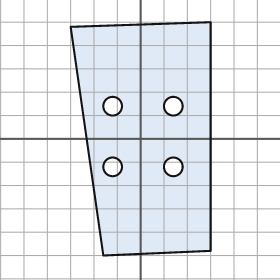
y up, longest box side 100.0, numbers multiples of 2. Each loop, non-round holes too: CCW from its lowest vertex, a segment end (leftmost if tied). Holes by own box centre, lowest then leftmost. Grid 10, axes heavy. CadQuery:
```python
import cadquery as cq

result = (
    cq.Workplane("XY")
    .moveTo(-16.0, -50.0)
    .lineTo(30.0, -48.0)
    .lineTo(30.0, 50.0)
    .lineTo(-30.0, 48.0)
    .close()
    .moveTo(-12.0, -12.0)
    .circle(4.0)
    .moveTo(14.0, -12.0)
    .circle(4.0)
    .moveTo(-12.0, 14.0)
    .circle(4.0)
    .moveTo(14.0, 14.0)
    .circle(4.0)
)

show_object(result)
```